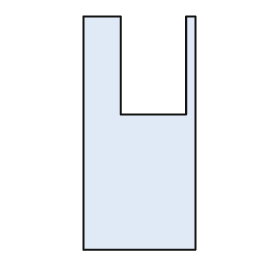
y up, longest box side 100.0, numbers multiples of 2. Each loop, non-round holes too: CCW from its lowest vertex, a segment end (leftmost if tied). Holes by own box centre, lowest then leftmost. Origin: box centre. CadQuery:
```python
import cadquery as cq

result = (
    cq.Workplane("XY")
    .moveTo(-24.0, -50.0)
    .lineTo(24.0, -50.0)
    .lineTo(24.0, 50.0)
    .lineTo(20.0, 50.0)
    .lineTo(20.0, 8.0)
    .lineTo(-8.0, 8.0)
    .lineTo(-8.0, 50.0)
    .lineTo(-24.0, 50.0)
    .close()
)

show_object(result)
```